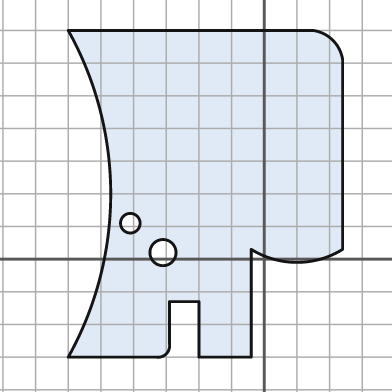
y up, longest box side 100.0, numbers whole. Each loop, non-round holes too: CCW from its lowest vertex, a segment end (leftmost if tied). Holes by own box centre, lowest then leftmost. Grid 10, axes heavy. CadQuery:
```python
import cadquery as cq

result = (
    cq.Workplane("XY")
    .moveTo(-60.0, -30.0)
    .lineTo(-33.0, -30.0)
    .threePointArc((-30.0, -29.0), (-29.0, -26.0))
    .lineTo(-29.0, -13.0)
    .lineTo(-20.0, -13.0)
    .lineTo(-20.0, -30.0)
    .lineTo(-4.0, -30.0)
    .lineTo(-4.0, 3.0)
    .threePointArc((10.0, -1.0), (24.0, 3.0))
    .lineTo(24.0, 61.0)
    .threePointArc((21.0, 67.0), (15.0, 70.0))
    .lineTo(-60.0, 70.0)
    .threePointArc((-47.0, 20.0), (-60.0, -30.0))
    .close()
    .moveTo(-31.0, 2.0)
    .circle(4.0)
    .moveTo(-41.0, 11.0)
    .circle(3.0)
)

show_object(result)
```